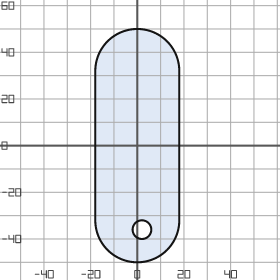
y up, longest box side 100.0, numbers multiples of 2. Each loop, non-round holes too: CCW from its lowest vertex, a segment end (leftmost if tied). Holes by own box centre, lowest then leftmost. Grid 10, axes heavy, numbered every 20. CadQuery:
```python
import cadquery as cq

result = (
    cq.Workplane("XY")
    .moveTo(-18.0, -32.0)
    .threePointArc((0.0, -50.0), (18.0, -32.0))
    .lineTo(18.0, 32.0)
    .threePointArc((0.0, 50.0), (-18.0, 32.0))
    .close()
    .moveTo(2.0, -36.0)
    .circle(4.0)
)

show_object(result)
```